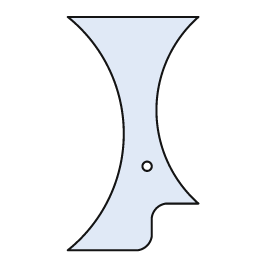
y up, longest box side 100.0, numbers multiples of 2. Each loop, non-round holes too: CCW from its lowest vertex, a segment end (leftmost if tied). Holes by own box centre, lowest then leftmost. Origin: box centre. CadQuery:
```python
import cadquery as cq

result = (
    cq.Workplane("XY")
    .moveTo(-28.0, -50.0)
    .lineTo(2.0, -50.0)
    .threePointArc((6.0, -48.0), (8.0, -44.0))
    .lineTo(8.0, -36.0)
    .threePointArc((10.0, -32.0), (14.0, -30.0))
    .lineTo(28.0, -30.0)
    .threePointArc((10.0, 10.0), (28.0, 50.0))
    .lineTo(-28.0, 50.0)
    .threePointArc((-4.0, 0.0), (-28.0, -50.0))
    .close()
    .moveTo(6.0, -14.0)
    .circle(2.0)
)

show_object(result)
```